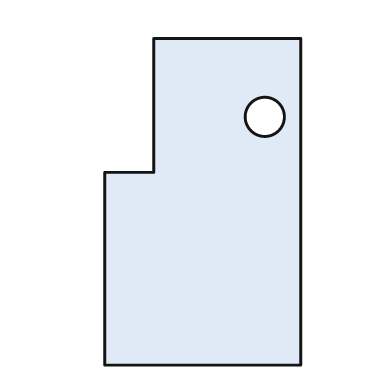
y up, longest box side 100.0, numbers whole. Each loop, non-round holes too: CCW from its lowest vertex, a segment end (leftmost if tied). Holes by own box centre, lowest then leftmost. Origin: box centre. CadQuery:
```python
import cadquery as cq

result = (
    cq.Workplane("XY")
    .moveTo(-30.0, -50.0)
    .lineTo(30.0, -50.0)
    .lineTo(30.0, 50.0)
    .lineTo(-15.0, 50.0)
    .lineTo(-15.0, 9.0)
    .lineTo(-30.0, 9.0)
    .close()
    .moveTo(19.0, 26.0)
    .circle(6.0)
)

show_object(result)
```